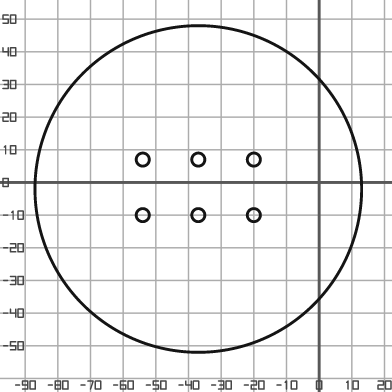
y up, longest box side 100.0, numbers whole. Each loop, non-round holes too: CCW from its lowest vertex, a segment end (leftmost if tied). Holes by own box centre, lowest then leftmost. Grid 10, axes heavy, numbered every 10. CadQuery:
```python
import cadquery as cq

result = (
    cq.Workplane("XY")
    .moveTo(-37.0, -2.0)
    .circle(50.0)
    .moveTo(-54.0, -10.0)
    .circle(2.0)
    .moveTo(-37.0, -10.0)
    .circle(2.0)
    .moveTo(-20.0, -10.0)
    .circle(2.0)
    .moveTo(-54.0, 7.0)
    .circle(2.0)
    .moveTo(-37.0, 7.0)
    .circle(2.0)
    .moveTo(-20.0, 7.0)
    .circle(2.0)
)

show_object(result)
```